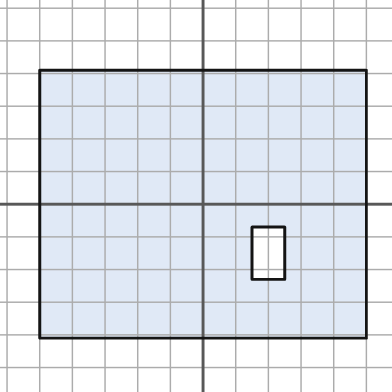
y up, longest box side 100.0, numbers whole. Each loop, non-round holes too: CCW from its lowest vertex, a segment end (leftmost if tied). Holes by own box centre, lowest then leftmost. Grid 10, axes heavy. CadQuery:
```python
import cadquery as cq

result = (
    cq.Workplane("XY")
    .moveTo(-50.0, -41.0)
    .lineTo(50.0, -41.0)
    .lineTo(50.0, 41.0)
    .lineTo(-50.0, 41.0)
    .close()
    .moveTo(15.0, -23.0)
    .lineTo(25.0, -23.0)
    .lineTo(25.0, -7.0)
    .lineTo(15.0, -7.0)
    .close()
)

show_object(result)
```